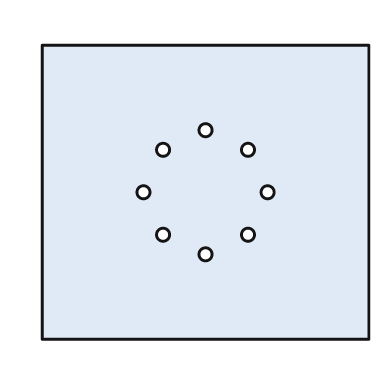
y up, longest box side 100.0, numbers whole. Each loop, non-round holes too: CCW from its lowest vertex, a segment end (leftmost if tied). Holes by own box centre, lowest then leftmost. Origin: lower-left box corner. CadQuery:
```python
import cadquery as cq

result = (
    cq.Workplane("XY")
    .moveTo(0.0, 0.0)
    .lineTo(100.0, 0.0)
    .lineTo(100.0, 90.0)
    .lineTo(0.0, 90.0)
    .close()
    .moveTo(50.0, 26.0)
    .circle(2.0)
    .moveTo(37.0, 32.0)
    .circle(2.0)
    .moveTo(63.0, 32.0)
    .circle(2.0)
    .moveTo(31.0, 45.0)
    .circle(2.0)
    .moveTo(69.0, 45.0)
    .circle(2.0)
    .moveTo(37.0, 58.0)
    .circle(2.0)
    .moveTo(63.0, 58.0)
    .circle(2.0)
    .moveTo(50.0, 64.0)
    .circle(2.0)
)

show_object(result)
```